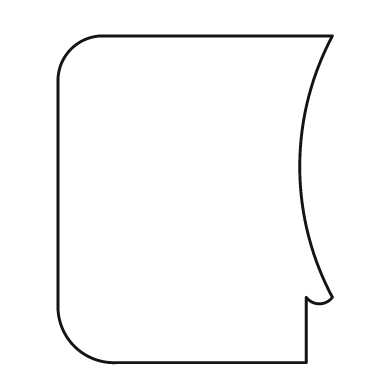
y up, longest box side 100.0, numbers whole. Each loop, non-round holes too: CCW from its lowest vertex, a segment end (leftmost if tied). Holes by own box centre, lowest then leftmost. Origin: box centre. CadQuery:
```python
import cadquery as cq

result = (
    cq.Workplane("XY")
    .moveTo(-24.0, -50.0)
    .lineTo(34.0, -50.0)
    .lineTo(34.0, -30.0)
    .threePointArc((38.0, -32.0), (42.0, -30.0))
    .threePointArc((32.0, 10.0), (42.0, 50.0))
    .lineTo(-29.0, 50.0)
    .threePointArc((-38.0, 46.0), (-42.0, 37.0))
    .lineTo(-42.0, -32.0)
    .threePointArc((-37.0, -45.0), (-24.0, -50.0))
    .close()
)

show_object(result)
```